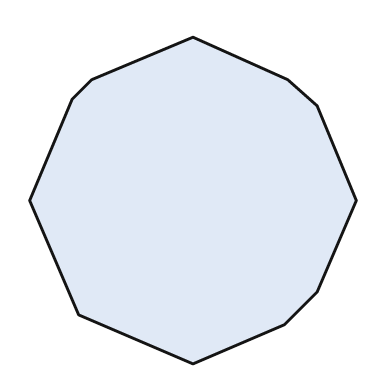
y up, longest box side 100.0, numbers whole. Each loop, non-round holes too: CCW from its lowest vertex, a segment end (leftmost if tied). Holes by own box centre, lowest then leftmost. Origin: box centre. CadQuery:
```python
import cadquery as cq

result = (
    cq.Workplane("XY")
    .moveTo(0.0, -50.0)
    .lineTo(28.0, -38.0)
    .lineTo(38.0, -28.0)
    .lineTo(50.0, 0.0)
    .lineTo(38.0, 29.0)
    .lineTo(29.0, 37.0)
    .lineTo(0.0, 50.0)
    .lineTo(-31.0, 37.0)
    .lineTo(-37.0, 31.0)
    .lineTo(-50.0, 0.0)
    .lineTo(-35.0, -35.0)
    .close()
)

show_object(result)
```